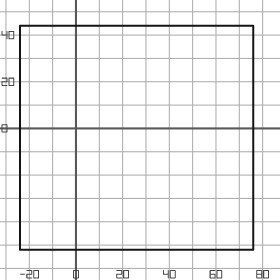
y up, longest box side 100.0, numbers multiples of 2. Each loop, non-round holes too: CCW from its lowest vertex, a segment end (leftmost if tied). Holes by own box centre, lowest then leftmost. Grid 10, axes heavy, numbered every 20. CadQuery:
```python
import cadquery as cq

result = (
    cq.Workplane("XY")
    .moveTo(-24.0, -52.0)
    .lineTo(76.0, -52.0)
    .lineTo(76.0, 44.0)
    .lineTo(-24.0, 44.0)
    .close()
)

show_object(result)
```